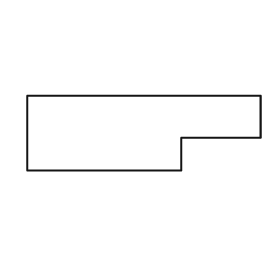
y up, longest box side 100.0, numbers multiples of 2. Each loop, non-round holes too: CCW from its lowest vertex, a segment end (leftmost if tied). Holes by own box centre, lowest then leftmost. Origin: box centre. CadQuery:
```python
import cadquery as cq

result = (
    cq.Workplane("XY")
    .moveTo(-50.0, -16.0)
    .lineTo(16.0, -16.0)
    .lineTo(16.0, -2.0)
    .lineTo(50.0, -2.0)
    .lineTo(50.0, 16.0)
    .lineTo(-50.0, 16.0)
    .close()
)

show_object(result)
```